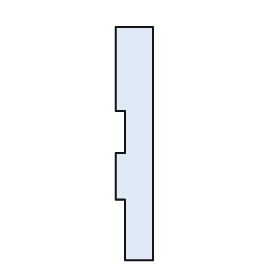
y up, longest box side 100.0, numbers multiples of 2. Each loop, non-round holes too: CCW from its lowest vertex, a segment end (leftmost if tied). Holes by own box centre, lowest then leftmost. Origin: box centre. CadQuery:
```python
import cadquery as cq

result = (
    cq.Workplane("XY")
    .moveTo(-4.0, -50.0)
    .lineTo(8.0, -50.0)
    .lineTo(8.0, 50.0)
    .lineTo(-8.0, 50.0)
    .lineTo(-8.0, 14.0)
    .lineTo(-4.0, 14.0)
    .lineTo(-4.0, -4.0)
    .lineTo(-8.0, -4.0)
    .lineTo(-8.0, -24.0)
    .lineTo(-4.0, -24.0)
    .close()
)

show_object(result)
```